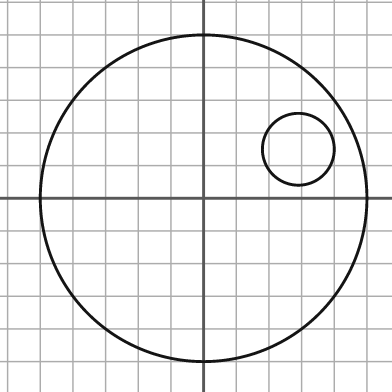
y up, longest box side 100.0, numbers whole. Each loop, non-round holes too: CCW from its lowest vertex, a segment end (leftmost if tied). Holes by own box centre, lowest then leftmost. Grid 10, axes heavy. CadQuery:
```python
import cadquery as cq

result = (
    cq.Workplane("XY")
    .moveTo(0.0, 0.0)
    .circle(50.0)
    .moveTo(29.0, 15.0)
    .circle(11.0)
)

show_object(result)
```